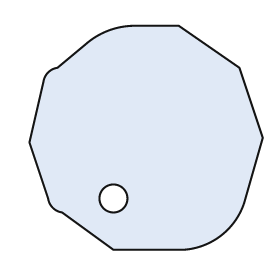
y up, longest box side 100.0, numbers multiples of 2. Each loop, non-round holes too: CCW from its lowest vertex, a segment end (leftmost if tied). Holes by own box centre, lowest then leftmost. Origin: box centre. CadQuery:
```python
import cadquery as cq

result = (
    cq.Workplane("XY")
    .moveTo(-14.0, -48.0)
    .lineTo(16.0, -48.0)
    .threePointArc((32.0, -42.0), (42.0, -28.0))
    .lineTo(50.0, 0.0)
    .lineTo(40.0, 30.0)
    .lineTo(14.0, 48.0)
    .lineTo(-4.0, 48.0)
    .threePointArc((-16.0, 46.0), (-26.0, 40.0))
    .lineTo(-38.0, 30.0)
    .threePointArc((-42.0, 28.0), (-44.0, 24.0))
    .lineTo(-50.0, -2.0)
    .lineTo(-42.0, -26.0)
    .threePointArc((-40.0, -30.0), (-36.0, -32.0))
    .close()
    .moveTo(-14.0, -26.0)
    .circle(6.0)
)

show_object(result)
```